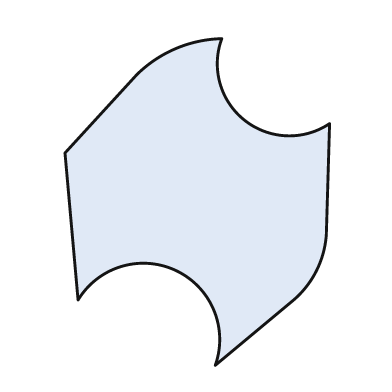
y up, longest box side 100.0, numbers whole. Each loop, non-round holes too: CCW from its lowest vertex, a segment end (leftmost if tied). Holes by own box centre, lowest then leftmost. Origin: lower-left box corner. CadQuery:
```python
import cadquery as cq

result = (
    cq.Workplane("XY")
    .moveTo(46.0, 0.0)
    .lineTo(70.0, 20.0)
    .threePointArc((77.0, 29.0), (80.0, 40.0))
    .lineTo(81.0, 74.0)
    .threePointArc((55.0, 75.0), (48.0, 100.0))
    .threePointArc((34.0, 97.0), (22.0, 89.0))
    .lineTo(0.0, 65.0)
    .lineTo(4.0, 20.0)
    .threePointArc((34.0, 29.0), (46.0, 0.0))
    .close()
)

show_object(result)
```